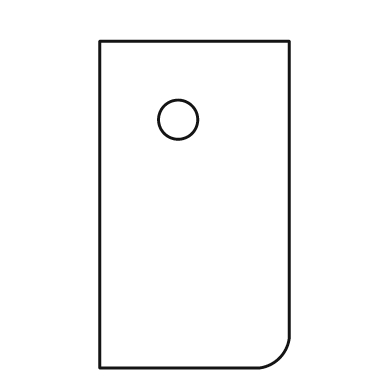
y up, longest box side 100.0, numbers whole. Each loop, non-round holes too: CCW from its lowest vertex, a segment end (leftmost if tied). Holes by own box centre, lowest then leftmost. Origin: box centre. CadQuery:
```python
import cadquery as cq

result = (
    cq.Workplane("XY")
    .moveTo(-29.0, -50.0)
    .lineTo(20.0, -50.0)
    .threePointArc((26.0, -47.0), (29.0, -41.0))
    .lineTo(29.0, 50.0)
    .lineTo(-29.0, 50.0)
    .close()
    .moveTo(-5.0, 26.0)
    .circle(6.0)
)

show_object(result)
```